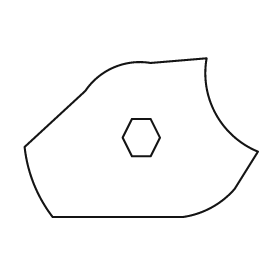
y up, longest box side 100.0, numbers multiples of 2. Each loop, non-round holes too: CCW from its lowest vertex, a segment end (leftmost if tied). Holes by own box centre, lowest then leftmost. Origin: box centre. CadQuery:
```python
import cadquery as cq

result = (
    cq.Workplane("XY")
    .moveTo(-38.0, -34.0)
    .lineTo(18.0, -34.0)
    .threePointArc((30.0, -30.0), (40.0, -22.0))
    .lineTo(50.0, -6.0)
    .threePointArc((32.0, 10.0), (28.0, 34.0))
    .lineTo(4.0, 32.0)
    .threePointArc((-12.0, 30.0), (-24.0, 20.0))
    .lineTo(-50.0, -4.0)
    .threePointArc((-46.0, -20.0), (-38.0, -34.0))
    .close()
    .moveTo(-4.0, -8.0)
    .lineTo(4.0, -8.0)
    .lineTo(8.0, 0.0)
    .lineTo(4.0, 8.0)
    .lineTo(-4.0, 8.0)
    .lineTo(-8.0, 0.0)
    .close()
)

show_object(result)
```